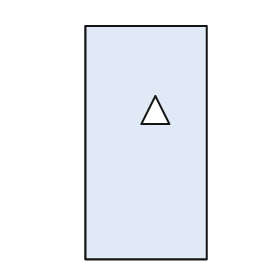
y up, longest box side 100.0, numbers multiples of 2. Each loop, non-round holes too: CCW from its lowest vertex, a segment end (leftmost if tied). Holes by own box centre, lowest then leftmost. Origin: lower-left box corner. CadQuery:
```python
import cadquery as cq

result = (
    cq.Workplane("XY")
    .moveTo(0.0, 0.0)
    .lineTo(52.0, 0.0)
    .lineTo(52.0, 100.0)
    .lineTo(0.0, 100.0)
    .close()
    .moveTo(24.0, 58.0)
    .lineTo(36.0, 58.0)
    .lineTo(30.0, 70.0)
    .close()
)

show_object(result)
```